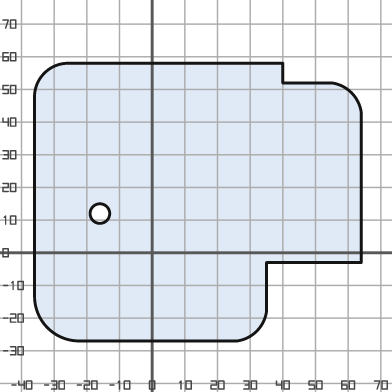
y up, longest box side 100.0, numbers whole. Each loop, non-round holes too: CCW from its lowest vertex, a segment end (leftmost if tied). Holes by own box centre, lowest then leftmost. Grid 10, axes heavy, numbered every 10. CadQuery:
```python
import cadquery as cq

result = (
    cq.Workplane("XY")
    .moveTo(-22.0, -27.0)
    .lineTo(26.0, -27.0)
    .threePointArc((32.0, -24.0), (35.0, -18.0))
    .lineTo(35.0, -3.0)
    .lineTo(64.0, -3.0)
    .lineTo(64.0, 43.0)
    .threePointArc((61.0, 49.0), (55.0, 52.0))
    .lineTo(40.0, 52.0)
    .lineTo(40.0, 58.0)
    .lineTo(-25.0, 58.0)
    .threePointArc((-33.0, 55.0), (-36.0, 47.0))
    .lineTo(-36.0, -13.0)
    .threePointArc((-32.0, -23.0), (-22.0, -27.0))
    .close()
    .moveTo(-16.0, 12.0)
    .circle(3.0)
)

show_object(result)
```